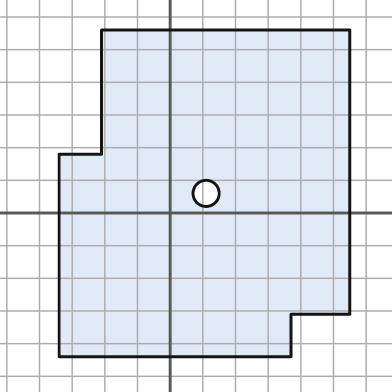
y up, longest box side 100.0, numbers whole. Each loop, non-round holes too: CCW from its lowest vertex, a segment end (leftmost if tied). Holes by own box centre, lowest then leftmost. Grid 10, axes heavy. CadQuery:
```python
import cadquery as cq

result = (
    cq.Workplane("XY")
    .moveTo(-34.0, -44.0)
    .lineTo(37.0, -44.0)
    .lineTo(37.0, -31.0)
    .lineTo(55.0, -31.0)
    .lineTo(55.0, 56.0)
    .lineTo(-21.0, 56.0)
    .lineTo(-21.0, 18.0)
    .lineTo(-34.0, 18.0)
    .close()
    .moveTo(11.0, 6.0)
    .circle(4.0)
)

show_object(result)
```